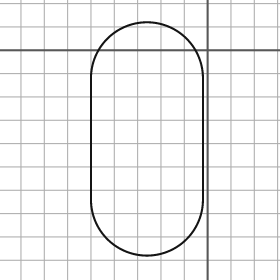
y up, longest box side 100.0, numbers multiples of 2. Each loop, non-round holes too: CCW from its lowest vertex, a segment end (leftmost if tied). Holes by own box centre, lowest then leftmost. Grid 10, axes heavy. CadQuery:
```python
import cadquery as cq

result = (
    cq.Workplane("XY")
    .moveTo(-50.0, -64.0)
    .threePointArc((-26.0, -88.0), (-2.0, -64.0))
    .lineTo(-2.0, -12.0)
    .threePointArc((-26.0, 12.0), (-50.0, -12.0))
    .close()
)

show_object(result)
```